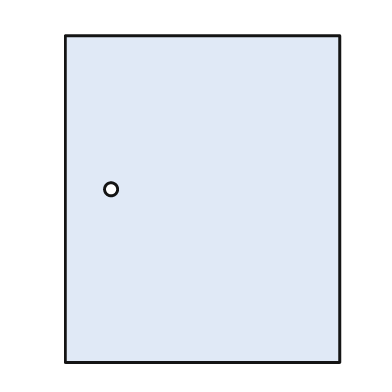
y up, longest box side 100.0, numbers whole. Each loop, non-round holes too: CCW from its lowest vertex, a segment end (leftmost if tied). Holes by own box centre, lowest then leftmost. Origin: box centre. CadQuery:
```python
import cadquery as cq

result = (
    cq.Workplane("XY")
    .moveTo(-42.0, -50.0)
    .lineTo(42.0, -50.0)
    .lineTo(42.0, 50.0)
    .lineTo(-42.0, 50.0)
    .close()
    .moveTo(-28.0, 3.0)
    .circle(2.0)
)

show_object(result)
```